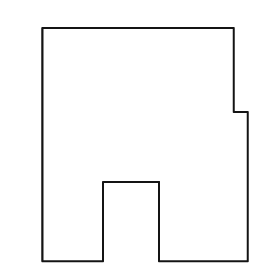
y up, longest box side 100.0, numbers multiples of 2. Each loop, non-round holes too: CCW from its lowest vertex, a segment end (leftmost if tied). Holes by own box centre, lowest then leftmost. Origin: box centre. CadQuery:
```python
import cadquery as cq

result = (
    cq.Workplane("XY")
    .moveTo(-44.0, -50.0)
    .lineTo(-18.0, -50.0)
    .lineTo(-18.0, -16.0)
    .lineTo(6.0, -16.0)
    .lineTo(6.0, -50.0)
    .lineTo(44.0, -50.0)
    .lineTo(44.0, 14.0)
    .lineTo(38.0, 14.0)
    .lineTo(38.0, 50.0)
    .lineTo(-44.0, 50.0)
    .close()
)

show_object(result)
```